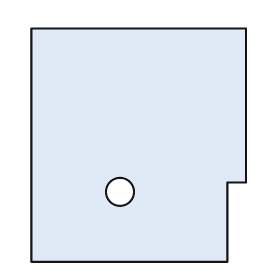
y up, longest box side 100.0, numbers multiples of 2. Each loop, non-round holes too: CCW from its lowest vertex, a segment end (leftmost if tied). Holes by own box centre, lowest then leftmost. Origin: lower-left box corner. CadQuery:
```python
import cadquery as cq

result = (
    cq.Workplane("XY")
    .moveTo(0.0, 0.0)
    .lineTo(84.0, 0.0)
    .lineTo(84.0, 34.0)
    .lineTo(92.0, 34.0)
    .lineTo(92.0, 100.0)
    .lineTo(0.0, 100.0)
    .close()
    .moveTo(38.0, 30.0)
    .circle(6.0)
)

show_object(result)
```